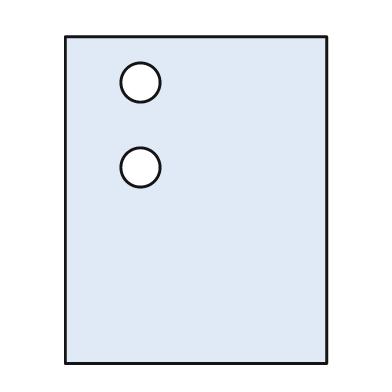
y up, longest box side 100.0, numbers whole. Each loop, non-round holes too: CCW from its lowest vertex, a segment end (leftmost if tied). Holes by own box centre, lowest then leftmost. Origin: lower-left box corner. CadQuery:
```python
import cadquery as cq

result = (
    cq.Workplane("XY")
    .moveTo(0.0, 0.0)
    .lineTo(80.0, 0.0)
    .lineTo(80.0, 100.0)
    .lineTo(0.0, 100.0)
    .close()
    .moveTo(23.0, 60.0)
    .circle(6.0)
    .moveTo(23.0, 86.0)
    .circle(6.0)
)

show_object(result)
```